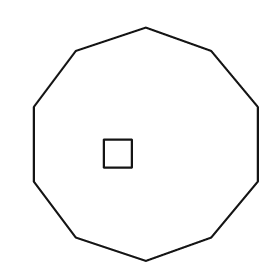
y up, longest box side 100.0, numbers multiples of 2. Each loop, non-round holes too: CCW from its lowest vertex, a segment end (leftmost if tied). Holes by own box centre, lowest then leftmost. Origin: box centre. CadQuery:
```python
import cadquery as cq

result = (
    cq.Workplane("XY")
    .moveTo(0.0, -50.0)
    .lineTo(28.0, -40.0)
    .lineTo(48.0, -16.0)
    .lineTo(48.0, 16.0)
    .lineTo(28.0, 40.0)
    .lineTo(0.0, 50.0)
    .lineTo(-30.0, 40.0)
    .lineTo(-48.0, 16.0)
    .lineTo(-48.0, -16.0)
    .lineTo(-30.0, -40.0)
    .close()
    .moveTo(-18.0, -10.0)
    .lineTo(-6.0, -10.0)
    .lineTo(-6.0, 2.0)
    .lineTo(-18.0, 2.0)
    .close()
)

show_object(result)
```